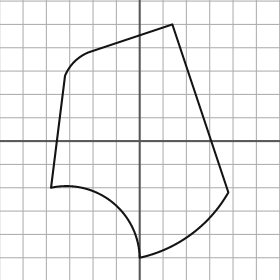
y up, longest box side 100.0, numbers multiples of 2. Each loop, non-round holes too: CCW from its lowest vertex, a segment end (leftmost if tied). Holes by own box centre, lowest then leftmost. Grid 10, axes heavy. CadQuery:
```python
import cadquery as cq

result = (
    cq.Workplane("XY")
    .moveTo(0.0, -50.0)
    .threePointArc((22.0, -40.0), (38.0, -22.0))
    .lineTo(14.0, 50.0)
    .lineTo(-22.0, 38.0)
    .threePointArc((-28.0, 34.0), (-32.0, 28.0))
    .lineTo(-38.0, -20.0)
    .threePointArc((-12.0, -26.0), (0.0, -50.0))
    .close()
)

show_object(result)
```